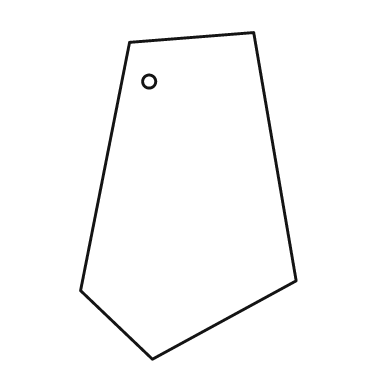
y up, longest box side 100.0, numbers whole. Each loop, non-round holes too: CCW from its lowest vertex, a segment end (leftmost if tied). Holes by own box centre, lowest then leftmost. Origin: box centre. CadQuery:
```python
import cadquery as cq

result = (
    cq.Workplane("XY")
    .moveTo(-11.0, -50.0)
    .lineTo(33.0, -26.0)
    .lineTo(20.0, 50.0)
    .lineTo(-18.0, 47.0)
    .lineTo(-33.0, -29.0)
    .close()
    .moveTo(-12.0, 35.0)
    .circle(2.0)
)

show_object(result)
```